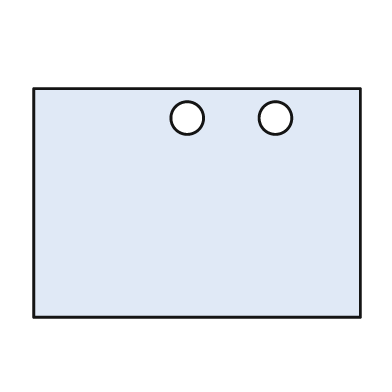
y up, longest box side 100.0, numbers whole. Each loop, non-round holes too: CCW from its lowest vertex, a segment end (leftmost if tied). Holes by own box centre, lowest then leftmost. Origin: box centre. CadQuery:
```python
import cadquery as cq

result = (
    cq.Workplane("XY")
    .moveTo(-50.0, -35.0)
    .lineTo(50.0, -35.0)
    .lineTo(50.0, 35.0)
    .lineTo(-50.0, 35.0)
    .close()
    .moveTo(-3.0, 26.0)
    .circle(5.0)
    .moveTo(24.0, 26.0)
    .circle(5.0)
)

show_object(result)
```